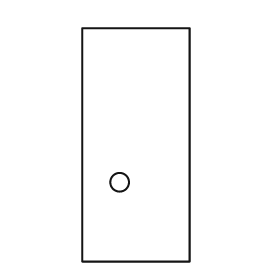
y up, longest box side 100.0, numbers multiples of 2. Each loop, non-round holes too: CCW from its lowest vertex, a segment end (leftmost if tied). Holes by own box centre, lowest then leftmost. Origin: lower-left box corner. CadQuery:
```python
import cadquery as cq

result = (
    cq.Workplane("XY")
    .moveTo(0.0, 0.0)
    .lineTo(46.0, 0.0)
    .lineTo(46.0, 100.0)
    .lineTo(0.0, 100.0)
    .close()
    .moveTo(16.0, 34.0)
    .circle(4.0)
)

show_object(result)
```